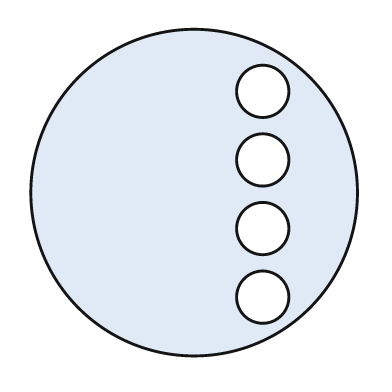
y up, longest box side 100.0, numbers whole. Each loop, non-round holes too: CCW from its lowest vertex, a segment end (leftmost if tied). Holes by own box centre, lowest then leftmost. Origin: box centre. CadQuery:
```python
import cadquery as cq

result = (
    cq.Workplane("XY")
    .moveTo(0.0, 0.0)
    .circle(50.0)
    .moveTo(21.0, -32.0)
    .circle(8.0)
    .moveTo(21.0, -11.0)
    .circle(8.0)
    .moveTo(21.0, 10.0)
    .circle(8.0)
    .moveTo(21.0, 31.0)
    .circle(8.0)
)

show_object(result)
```